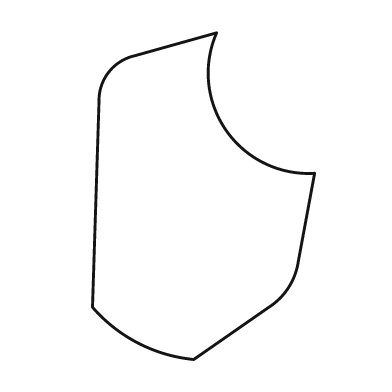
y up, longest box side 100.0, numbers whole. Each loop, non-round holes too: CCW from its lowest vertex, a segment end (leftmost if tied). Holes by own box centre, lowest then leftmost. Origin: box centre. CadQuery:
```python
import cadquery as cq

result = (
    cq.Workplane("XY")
    .moveTo(-3.0, -50.0)
    .lineTo(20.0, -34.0)
    .threePointArc((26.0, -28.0), (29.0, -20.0))
    .lineTo(34.0, 7.0)
    .threePointArc((7.0, 20.0), (4.0, 50.0))
    .lineTo(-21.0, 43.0)
    .threePointArc((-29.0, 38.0), (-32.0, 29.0))
    .lineTo(-34.0, -34.0)
    .threePointArc((-20.0, -45.0), (-3.0, -50.0))
    .close()
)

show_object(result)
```